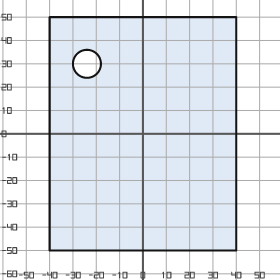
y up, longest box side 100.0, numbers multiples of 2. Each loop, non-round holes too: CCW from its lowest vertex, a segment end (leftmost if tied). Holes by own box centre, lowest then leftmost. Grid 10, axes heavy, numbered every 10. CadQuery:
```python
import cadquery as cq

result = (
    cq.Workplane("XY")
    .moveTo(-40.0, -50.0)
    .lineTo(40.0, -50.0)
    .lineTo(40.0, 50.0)
    .lineTo(-40.0, 50.0)
    .close()
    .moveTo(-24.0, 30.0)
    .circle(6.0)
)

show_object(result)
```